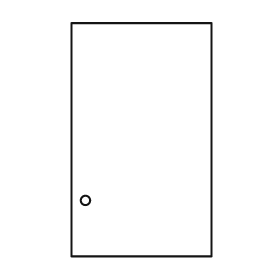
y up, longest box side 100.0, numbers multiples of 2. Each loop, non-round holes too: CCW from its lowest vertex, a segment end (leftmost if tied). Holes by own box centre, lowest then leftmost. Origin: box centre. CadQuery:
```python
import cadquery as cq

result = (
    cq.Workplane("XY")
    .moveTo(-30.0, -50.0)
    .lineTo(30.0, -50.0)
    .lineTo(30.0, 50.0)
    .lineTo(-30.0, 50.0)
    .close()
    .moveTo(-24.0, -26.0)
    .circle(2.0)
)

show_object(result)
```